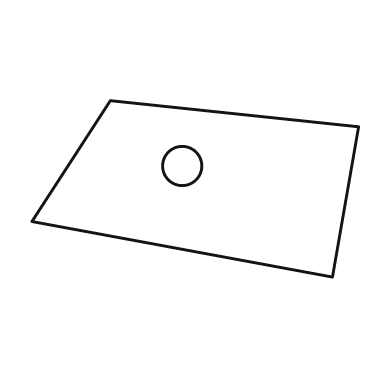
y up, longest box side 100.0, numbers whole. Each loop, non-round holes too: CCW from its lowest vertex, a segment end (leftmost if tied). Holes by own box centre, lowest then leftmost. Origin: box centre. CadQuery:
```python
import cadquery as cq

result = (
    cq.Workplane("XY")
    .moveTo(42.0, -27.0)
    .lineTo(50.0, 19.0)
    .lineTo(-26.0, 27.0)
    .lineTo(-50.0, -10.0)
    .close()
    .moveTo(-4.0, 7.0)
    .circle(6.0)
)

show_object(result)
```